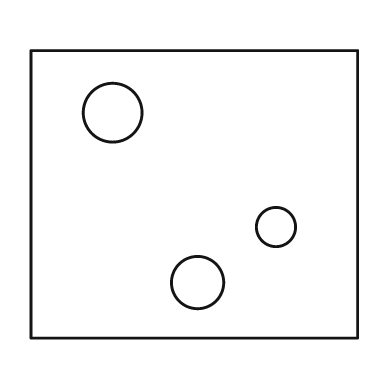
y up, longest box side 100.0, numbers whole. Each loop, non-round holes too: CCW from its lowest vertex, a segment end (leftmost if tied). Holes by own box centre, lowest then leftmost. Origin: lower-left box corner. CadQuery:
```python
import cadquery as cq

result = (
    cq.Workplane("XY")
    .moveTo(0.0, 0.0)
    .lineTo(100.0, 0.0)
    .lineTo(100.0, 88.0)
    .lineTo(0.0, 88.0)
    .close()
    .moveTo(51.0, 17.0)
    .circle(8.0)
    .moveTo(75.0, 34.0)
    .circle(6.0)
    .moveTo(25.0, 69.0)
    .circle(9.0)
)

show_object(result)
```